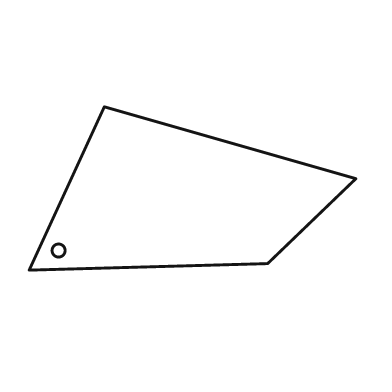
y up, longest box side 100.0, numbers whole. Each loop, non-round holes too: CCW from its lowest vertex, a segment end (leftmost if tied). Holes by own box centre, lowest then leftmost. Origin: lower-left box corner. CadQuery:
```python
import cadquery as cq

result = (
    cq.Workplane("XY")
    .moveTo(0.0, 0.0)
    .lineTo(73.0, 2.0)
    .lineTo(100.0, 28.0)
    .lineTo(23.0, 50.0)
    .close()
    .moveTo(9.0, 6.0)
    .circle(2.0)
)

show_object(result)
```